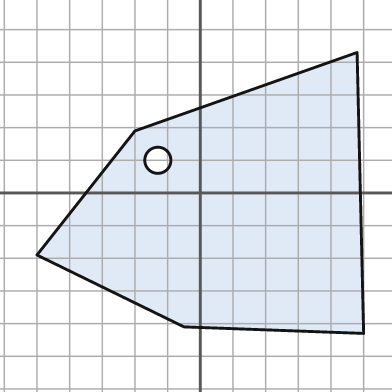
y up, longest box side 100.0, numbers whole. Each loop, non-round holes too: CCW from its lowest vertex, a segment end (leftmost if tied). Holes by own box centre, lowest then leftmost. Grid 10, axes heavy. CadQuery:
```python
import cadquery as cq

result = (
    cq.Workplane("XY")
    .moveTo(50.0, -43.0)
    .lineTo(48.0, 43.0)
    .lineTo(-20.0, 19.0)
    .lineTo(-50.0, -19.0)
    .lineTo(-5.0, -41.0)
    .close()
    .moveTo(-13.0, 10.0)
    .circle(4.0)
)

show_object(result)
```